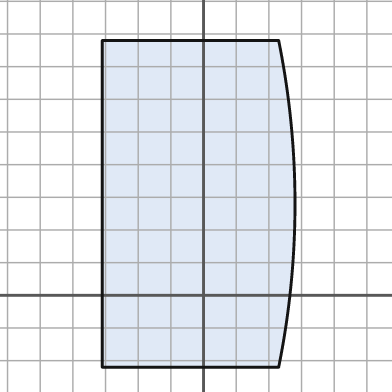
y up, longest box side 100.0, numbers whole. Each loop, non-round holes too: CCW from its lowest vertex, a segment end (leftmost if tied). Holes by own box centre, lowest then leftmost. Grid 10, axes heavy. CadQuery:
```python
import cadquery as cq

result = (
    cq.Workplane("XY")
    .moveTo(-31.0, -22.0)
    .lineTo(23.0, -22.0)
    .threePointArc((28.0, 28.0), (23.0, 78.0))
    .lineTo(-31.0, 78.0)
    .close()
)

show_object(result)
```